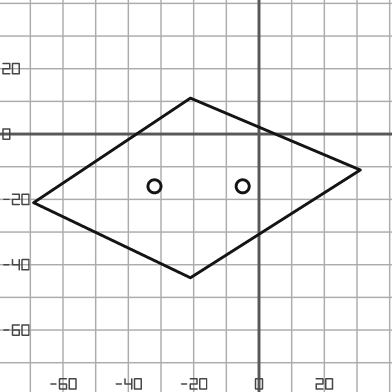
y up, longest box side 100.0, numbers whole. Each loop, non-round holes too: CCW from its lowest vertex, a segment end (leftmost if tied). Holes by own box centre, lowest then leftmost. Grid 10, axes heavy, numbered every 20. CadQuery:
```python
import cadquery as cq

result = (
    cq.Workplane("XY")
    .moveTo(-21.0, -44.0)
    .lineTo(31.0, -11.0)
    .lineTo(-21.0, 11.0)
    .lineTo(-69.0, -21.0)
    .close()
    .moveTo(-32.0, -16.0)
    .circle(2.0)
    .moveTo(-5.0, -16.0)
    .circle(2.0)
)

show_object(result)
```